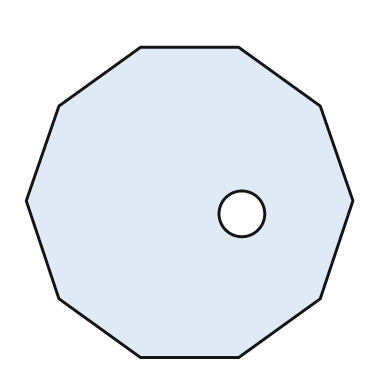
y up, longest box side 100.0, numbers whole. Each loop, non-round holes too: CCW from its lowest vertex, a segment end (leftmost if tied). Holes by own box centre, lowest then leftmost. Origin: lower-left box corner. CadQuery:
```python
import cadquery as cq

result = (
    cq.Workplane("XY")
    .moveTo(35.0, 0.0)
    .lineTo(65.0, 0.0)
    .lineTo(90.0, 18.0)
    .lineTo(100.0, 48.0)
    .lineTo(90.0, 77.0)
    .lineTo(65.0, 95.0)
    .lineTo(35.0, 95.0)
    .lineTo(10.0, 77.0)
    .lineTo(0.0, 48.0)
    .lineTo(10.0, 18.0)
    .close()
    .moveTo(66.0, 44.0)
    .circle(7.0)
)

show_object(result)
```